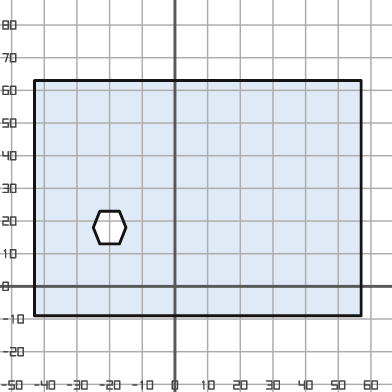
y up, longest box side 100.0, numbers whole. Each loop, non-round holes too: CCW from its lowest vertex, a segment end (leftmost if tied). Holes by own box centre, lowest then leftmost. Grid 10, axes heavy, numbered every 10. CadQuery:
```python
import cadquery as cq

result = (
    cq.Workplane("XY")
    .moveTo(-43.0, -9.0)
    .lineTo(57.0, -9.0)
    .lineTo(57.0, 63.0)
    .lineTo(-43.0, 63.0)
    .close()
    .moveTo(-23.0, 13.0)
    .lineTo(-17.0, 13.0)
    .lineTo(-15.0, 18.0)
    .lineTo(-17.0, 23.0)
    .lineTo(-23.0, 23.0)
    .lineTo(-25.0, 18.0)
    .close()
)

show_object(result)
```